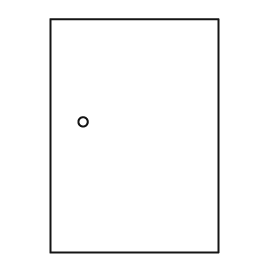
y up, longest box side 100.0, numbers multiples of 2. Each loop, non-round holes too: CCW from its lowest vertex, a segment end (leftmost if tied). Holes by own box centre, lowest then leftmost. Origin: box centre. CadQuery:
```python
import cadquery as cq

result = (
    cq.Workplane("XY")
    .moveTo(-36.0, -50.0)
    .lineTo(36.0, -50.0)
    .lineTo(36.0, 50.0)
    .lineTo(-36.0, 50.0)
    .close()
    .moveTo(-22.0, 6.0)
    .circle(2.0)
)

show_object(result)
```